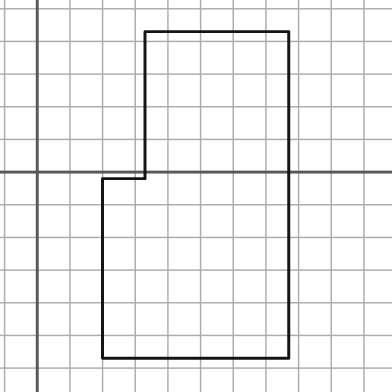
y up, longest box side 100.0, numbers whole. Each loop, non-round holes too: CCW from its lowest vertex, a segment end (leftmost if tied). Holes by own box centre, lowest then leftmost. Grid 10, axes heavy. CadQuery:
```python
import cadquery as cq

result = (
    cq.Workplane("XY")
    .moveTo(20.0, -57.0)
    .lineTo(77.0, -57.0)
    .lineTo(77.0, 43.0)
    .lineTo(33.0, 43.0)
    .lineTo(33.0, -2.0)
    .lineTo(20.0, -2.0)
    .close()
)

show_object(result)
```